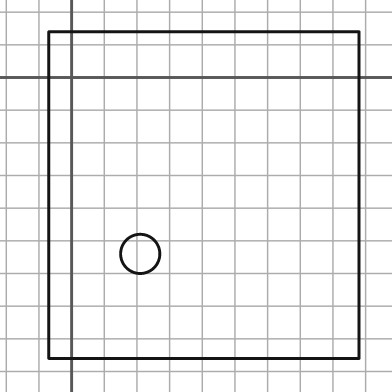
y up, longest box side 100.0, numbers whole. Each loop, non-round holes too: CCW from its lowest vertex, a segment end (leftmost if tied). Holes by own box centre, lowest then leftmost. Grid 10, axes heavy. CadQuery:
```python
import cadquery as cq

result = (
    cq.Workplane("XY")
    .moveTo(-7.0, -86.0)
    .lineTo(88.0, -86.0)
    .lineTo(88.0, 14.0)
    .lineTo(-7.0, 14.0)
    .close()
    .moveTo(21.0, -54.0)
    .circle(6.0)
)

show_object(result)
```